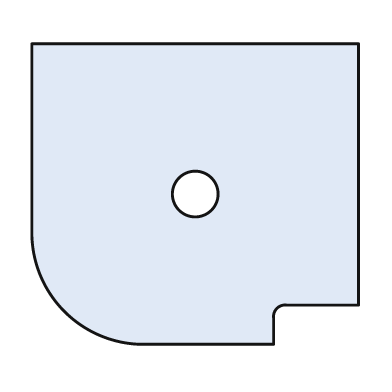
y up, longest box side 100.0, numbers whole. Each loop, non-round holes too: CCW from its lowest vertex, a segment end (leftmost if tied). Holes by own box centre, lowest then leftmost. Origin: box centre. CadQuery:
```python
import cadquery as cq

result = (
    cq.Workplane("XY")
    .moveTo(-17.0, -46.0)
    .lineTo(24.0, -46.0)
    .lineTo(24.0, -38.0)
    .threePointArc((25.0, -35.0), (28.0, -34.0))
    .lineTo(50.0, -34.0)
    .lineTo(50.0, 46.0)
    .lineTo(-50.0, 46.0)
    .lineTo(-50.0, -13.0)
    .threePointArc((-40.0, -36.0), (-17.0, -46.0))
    .close()
    .moveTo(0.0, 0.0)
    .circle(7.0)
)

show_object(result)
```